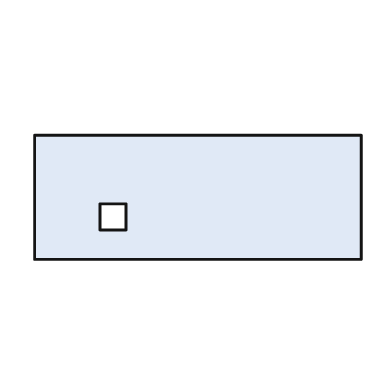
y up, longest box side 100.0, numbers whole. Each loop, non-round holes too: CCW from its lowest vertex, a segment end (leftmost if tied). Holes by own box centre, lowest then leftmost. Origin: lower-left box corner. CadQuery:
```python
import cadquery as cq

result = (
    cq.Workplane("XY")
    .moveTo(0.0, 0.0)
    .lineTo(100.0, 0.0)
    .lineTo(100.0, 38.0)
    .lineTo(0.0, 38.0)
    .close()
    .moveTo(20.0, 9.0)
    .lineTo(28.0, 9.0)
    .lineTo(28.0, 17.0)
    .lineTo(20.0, 17.0)
    .close()
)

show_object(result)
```